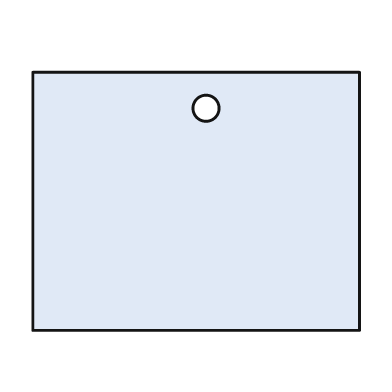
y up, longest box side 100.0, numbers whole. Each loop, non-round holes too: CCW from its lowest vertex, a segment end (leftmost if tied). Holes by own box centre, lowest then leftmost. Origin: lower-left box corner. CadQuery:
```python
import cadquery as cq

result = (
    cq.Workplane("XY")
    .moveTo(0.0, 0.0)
    .lineTo(100.0, 0.0)
    .lineTo(100.0, 79.0)
    .lineTo(0.0, 79.0)
    .close()
    .moveTo(53.0, 68.0)
    .circle(4.0)
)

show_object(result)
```